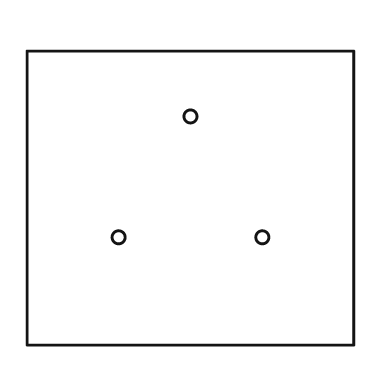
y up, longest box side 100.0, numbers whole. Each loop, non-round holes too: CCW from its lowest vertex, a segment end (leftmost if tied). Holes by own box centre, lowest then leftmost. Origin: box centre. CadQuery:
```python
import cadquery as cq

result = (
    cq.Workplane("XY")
    .moveTo(-50.0, -45.0)
    .lineTo(50.0, -45.0)
    .lineTo(50.0, 45.0)
    .lineTo(-50.0, 45.0)
    .close()
    .moveTo(-22.0, -12.0)
    .circle(2.0)
    .moveTo(22.0, -12.0)
    .circle(2.0)
    .moveTo(0.0, 25.0)
    .circle(2.0)
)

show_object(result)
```